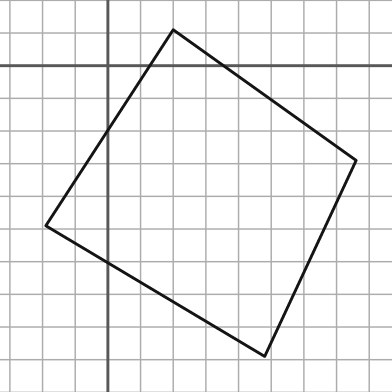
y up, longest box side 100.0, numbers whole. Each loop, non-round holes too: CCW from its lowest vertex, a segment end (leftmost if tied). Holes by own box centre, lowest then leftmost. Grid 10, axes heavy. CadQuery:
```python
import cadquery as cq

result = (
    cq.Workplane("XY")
    .moveTo(48.0, -89.0)
    .lineTo(76.0, -29.0)
    .lineTo(20.0, 11.0)
    .lineTo(-19.0, -49.0)
    .close()
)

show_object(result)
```